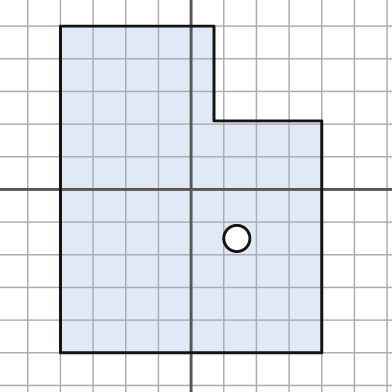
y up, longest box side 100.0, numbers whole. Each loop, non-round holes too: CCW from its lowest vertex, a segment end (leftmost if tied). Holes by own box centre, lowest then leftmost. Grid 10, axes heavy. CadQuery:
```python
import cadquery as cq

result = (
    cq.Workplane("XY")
    .moveTo(-40.0, -50.0)
    .lineTo(40.0, -50.0)
    .lineTo(40.0, 21.0)
    .lineTo(7.0, 21.0)
    .lineTo(7.0, 50.0)
    .lineTo(-40.0, 50.0)
    .close()
    .moveTo(14.0, -15.0)
    .circle(4.0)
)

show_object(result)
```